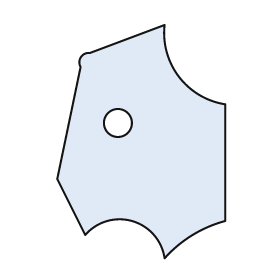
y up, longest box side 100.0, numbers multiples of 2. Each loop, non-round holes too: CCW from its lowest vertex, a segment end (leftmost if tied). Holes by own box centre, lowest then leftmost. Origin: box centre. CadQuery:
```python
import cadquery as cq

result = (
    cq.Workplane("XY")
    .moveTo(10.0, -50.0)
    .threePointArc((22.0, -40.0), (36.0, -34.0))
    .lineTo(36.0, 16.0)
    .threePointArc((16.0, 28.0), (10.0, 50.0))
    .lineTo(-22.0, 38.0)
    .threePointArc((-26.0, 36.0), (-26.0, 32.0))
    .lineTo(-36.0, -16.0)
    .lineTo(-24.0, -40.0)
    .threePointArc((-4.0, -34.0), (10.0, -50.0))
    .close()
    .moveTo(-10.0, 8.0)
    .circle(6.0)
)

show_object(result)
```